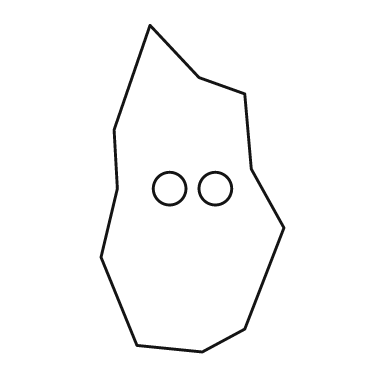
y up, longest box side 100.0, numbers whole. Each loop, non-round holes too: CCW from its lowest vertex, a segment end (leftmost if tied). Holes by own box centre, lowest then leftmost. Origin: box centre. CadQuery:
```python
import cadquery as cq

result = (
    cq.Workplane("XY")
    .moveTo(3.0, -50.0)
    .lineTo(16.0, -43.0)
    .lineTo(28.0, -12.0)
    .lineTo(18.0, 6.0)
    .lineTo(16.0, 29.0)
    .lineTo(2.0, 34.0)
    .lineTo(-13.0, 50.0)
    .lineTo(-24.0, 18.0)
    .lineTo(-23.0, 0.0)
    .lineTo(-28.0, -21.0)
    .lineTo(-17.0, -48.0)
    .close()
    .moveTo(-7.0, 0.0)
    .circle(5.0)
    .moveTo(7.0, 0.0)
    .circle(5.0)
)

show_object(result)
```